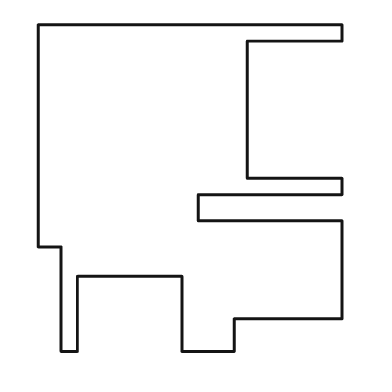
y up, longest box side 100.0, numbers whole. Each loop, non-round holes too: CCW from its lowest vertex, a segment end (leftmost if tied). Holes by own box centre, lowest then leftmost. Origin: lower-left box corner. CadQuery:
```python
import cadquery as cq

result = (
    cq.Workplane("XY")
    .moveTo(7.0, 0.0)
    .lineTo(12.0, 0.0)
    .lineTo(12.0, 23.0)
    .lineTo(44.0, 23.0)
    .lineTo(44.0, 0.0)
    .lineTo(60.0, 0.0)
    .lineTo(60.0, 10.0)
    .lineTo(93.0, 10.0)
    .lineTo(93.0, 40.0)
    .lineTo(49.0, 40.0)
    .lineTo(49.0, 48.0)
    .lineTo(93.0, 48.0)
    .lineTo(93.0, 53.0)
    .lineTo(64.0, 53.0)
    .lineTo(64.0, 95.0)
    .lineTo(93.0, 95.0)
    .lineTo(93.0, 100.0)
    .lineTo(0.0, 100.0)
    .lineTo(0.0, 32.0)
    .lineTo(7.0, 32.0)
    .close()
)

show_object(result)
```